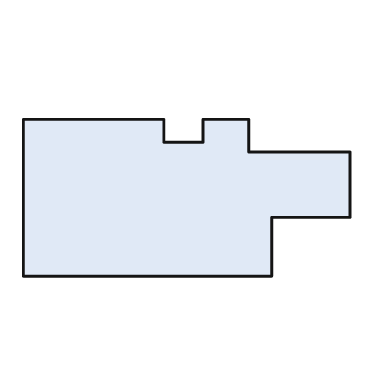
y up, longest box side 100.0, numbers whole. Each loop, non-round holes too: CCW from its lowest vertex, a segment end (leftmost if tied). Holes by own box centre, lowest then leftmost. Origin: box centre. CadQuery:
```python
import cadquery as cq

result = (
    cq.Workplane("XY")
    .moveTo(-50.0, -24.0)
    .lineTo(26.0, -24.0)
    .lineTo(26.0, -6.0)
    .lineTo(50.0, -6.0)
    .lineTo(50.0, 14.0)
    .lineTo(19.0, 14.0)
    .lineTo(19.0, 24.0)
    .lineTo(5.0, 24.0)
    .lineTo(5.0, 17.0)
    .lineTo(-7.0, 17.0)
    .lineTo(-7.0, 24.0)
    .lineTo(-50.0, 24.0)
    .close()
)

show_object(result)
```